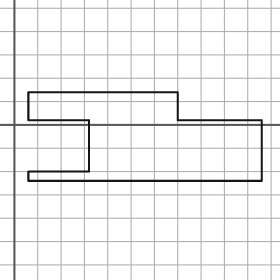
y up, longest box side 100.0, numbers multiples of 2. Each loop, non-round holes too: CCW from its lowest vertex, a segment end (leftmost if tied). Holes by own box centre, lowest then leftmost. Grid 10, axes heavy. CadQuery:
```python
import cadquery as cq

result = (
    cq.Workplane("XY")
    .moveTo(6.0, -24.0)
    .lineTo(106.0, -24.0)
    .lineTo(106.0, 2.0)
    .lineTo(70.0, 2.0)
    .lineTo(70.0, 14.0)
    .lineTo(6.0, 14.0)
    .lineTo(6.0, 2.0)
    .lineTo(32.0, 2.0)
    .lineTo(32.0, -20.0)
    .lineTo(6.0, -20.0)
    .close()
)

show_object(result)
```